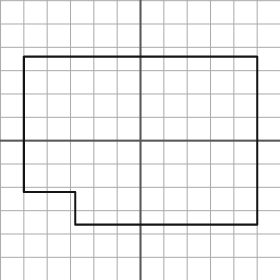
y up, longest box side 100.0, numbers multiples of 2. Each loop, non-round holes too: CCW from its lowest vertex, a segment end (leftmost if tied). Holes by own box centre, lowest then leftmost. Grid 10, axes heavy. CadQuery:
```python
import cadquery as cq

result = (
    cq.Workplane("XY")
    .moveTo(-28.0, -36.0)
    .lineTo(50.0, -36.0)
    .lineTo(50.0, 36.0)
    .lineTo(-50.0, 36.0)
    .lineTo(-50.0, -22.0)
    .lineTo(-28.0, -22.0)
    .close()
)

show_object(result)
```